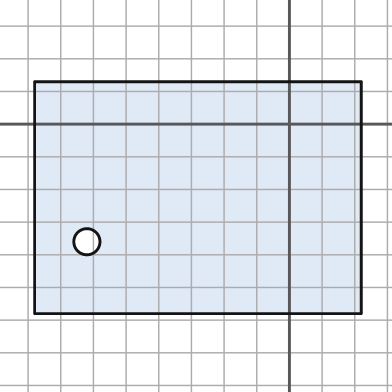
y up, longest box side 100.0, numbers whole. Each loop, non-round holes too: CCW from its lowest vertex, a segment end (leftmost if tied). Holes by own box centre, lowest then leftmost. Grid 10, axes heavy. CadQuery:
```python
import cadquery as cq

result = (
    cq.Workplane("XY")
    .moveTo(-78.0, -58.0)
    .lineTo(22.0, -58.0)
    .lineTo(22.0, 13.0)
    .lineTo(-78.0, 13.0)
    .close()
    .moveTo(-62.0, -36.0)
    .circle(4.0)
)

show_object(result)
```